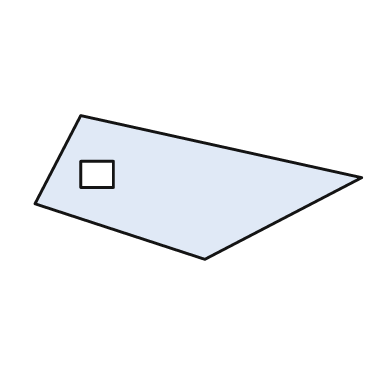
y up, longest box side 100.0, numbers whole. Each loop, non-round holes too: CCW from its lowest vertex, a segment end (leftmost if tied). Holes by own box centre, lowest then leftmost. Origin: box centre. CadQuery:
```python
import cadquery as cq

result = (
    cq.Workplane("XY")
    .moveTo(2.0, -22.0)
    .lineTo(50.0, 3.0)
    .lineTo(-36.0, 22.0)
    .lineTo(-50.0, -5.0)
    .close()
    .moveTo(-36.0, 0.0)
    .lineTo(-26.0, 0.0)
    .lineTo(-26.0, 8.0)
    .lineTo(-36.0, 8.0)
    .close()
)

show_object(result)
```